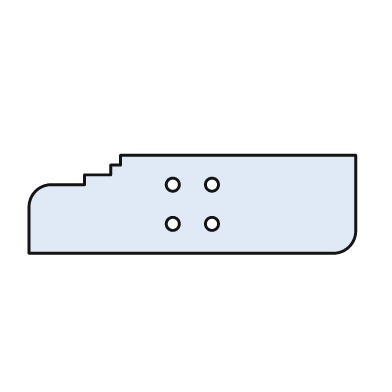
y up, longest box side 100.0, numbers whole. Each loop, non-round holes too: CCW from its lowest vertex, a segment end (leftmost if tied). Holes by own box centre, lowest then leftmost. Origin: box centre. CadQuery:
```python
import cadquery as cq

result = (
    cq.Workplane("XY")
    .moveTo(-50.0, -15.0)
    .lineTo(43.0, -15.0)
    .threePointArc((48.0, -13.0), (50.0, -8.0))
    .lineTo(50.0, 15.0)
    .lineTo(-22.0, 15.0)
    .lineTo(-22.0, 12.0)
    .lineTo(-25.0, 12.0)
    .lineTo(-25.0, 9.0)
    .lineTo(-33.0, 9.0)
    .lineTo(-33.0, 6.0)
    .lineTo(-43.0, 6.0)
    .threePointArc((-48.0, 4.0), (-50.0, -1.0))
    .close()
    .moveTo(-6.0, -6.0)
    .circle(2.0)
    .moveTo(6.0, -6.0)
    .circle(2.0)
    .moveTo(-6.0, 6.0)
    .circle(2.0)
    .moveTo(6.0, 6.0)
    .circle(2.0)
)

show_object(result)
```